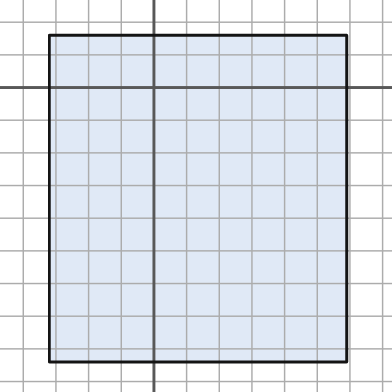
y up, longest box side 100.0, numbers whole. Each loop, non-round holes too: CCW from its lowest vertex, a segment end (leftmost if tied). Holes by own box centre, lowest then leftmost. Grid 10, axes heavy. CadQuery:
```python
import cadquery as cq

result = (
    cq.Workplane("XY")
    .moveTo(-32.0, -84.0)
    .lineTo(59.0, -84.0)
    .lineTo(59.0, 16.0)
    .lineTo(-32.0, 16.0)
    .close()
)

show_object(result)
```